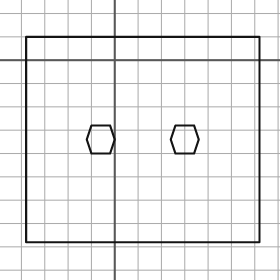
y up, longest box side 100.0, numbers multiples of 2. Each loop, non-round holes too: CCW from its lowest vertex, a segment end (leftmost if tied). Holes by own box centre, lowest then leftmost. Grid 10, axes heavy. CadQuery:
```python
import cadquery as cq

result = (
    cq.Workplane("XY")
    .moveTo(-38.0, -78.0)
    .lineTo(62.0, -78.0)
    .lineTo(62.0, 10.0)
    .lineTo(-38.0, 10.0)
    .close()
    .moveTo(-10.0, -40.0)
    .lineTo(-2.0, -40.0)
    .lineTo(0.0, -34.0)
    .lineTo(-2.0, -28.0)
    .lineTo(-10.0, -28.0)
    .lineTo(-12.0, -34.0)
    .close()
    .moveTo(26.0, -40.0)
    .lineTo(34.0, -40.0)
    .lineTo(36.0, -34.0)
    .lineTo(34.0, -28.0)
    .lineTo(26.0, -28.0)
    .lineTo(24.0, -34.0)
    .close()
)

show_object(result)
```